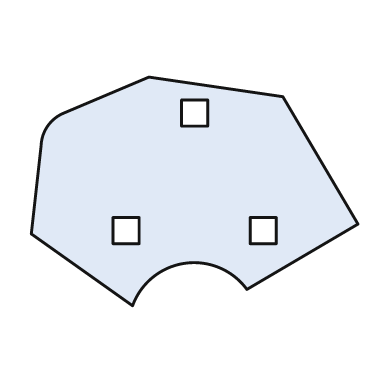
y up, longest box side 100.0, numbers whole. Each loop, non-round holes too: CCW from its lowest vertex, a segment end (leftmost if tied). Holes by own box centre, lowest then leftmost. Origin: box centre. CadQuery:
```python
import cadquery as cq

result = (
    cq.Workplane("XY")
    .moveTo(-19.0, -35.0)
    .threePointArc((-3.0, -22.0), (16.0, -30.0))
    .lineTo(50.0, -10.0)
    .lineTo(27.0, 29.0)
    .lineTo(-14.0, 35.0)
    .lineTo(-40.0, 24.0)
    .threePointArc((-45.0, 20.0), (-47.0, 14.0))
    .lineTo(-50.0, -13.0)
    .close()
    .moveTo(-25.0, -16.0)
    .lineTo(-17.0, -16.0)
    .lineTo(-17.0, -8.0)
    .lineTo(-25.0, -8.0)
    .close()
    .moveTo(17.0, -16.0)
    .lineTo(25.0, -16.0)
    .lineTo(25.0, -8.0)
    .lineTo(17.0, -8.0)
    .close()
    .moveTo(-4.0, 20.0)
    .lineTo(4.0, 20.0)
    .lineTo(4.0, 28.0)
    .lineTo(-4.0, 28.0)
    .close()
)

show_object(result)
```